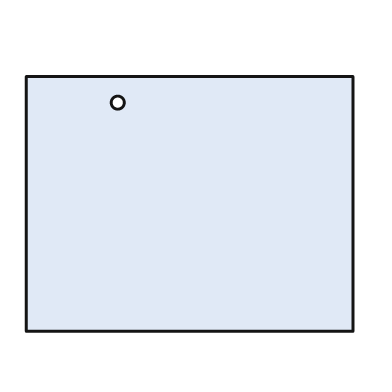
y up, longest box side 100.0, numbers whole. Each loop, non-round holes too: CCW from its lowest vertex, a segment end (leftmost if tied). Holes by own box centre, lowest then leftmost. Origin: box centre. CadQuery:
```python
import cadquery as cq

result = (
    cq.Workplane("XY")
    .moveTo(-50.0, -39.0)
    .lineTo(50.0, -39.0)
    .lineTo(50.0, 39.0)
    .lineTo(-50.0, 39.0)
    .close()
    .moveTo(-22.0, 31.0)
    .circle(2.0)
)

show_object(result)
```